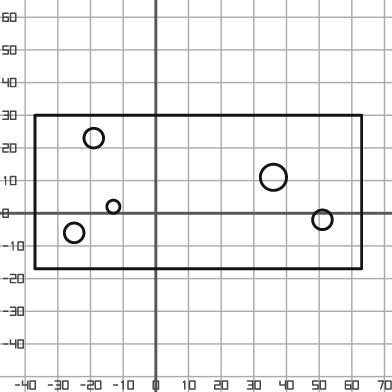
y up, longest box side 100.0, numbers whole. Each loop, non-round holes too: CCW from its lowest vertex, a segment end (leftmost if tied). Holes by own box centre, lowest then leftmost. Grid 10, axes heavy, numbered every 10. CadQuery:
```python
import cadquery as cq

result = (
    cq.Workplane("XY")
    .moveTo(-37.0, -17.0)
    .lineTo(63.0, -17.0)
    .lineTo(63.0, 30.0)
    .lineTo(-37.0, 30.0)
    .close()
    .moveTo(-25.0, -6.0)
    .circle(3.0)
    .moveTo(51.0, -2.0)
    .circle(3.0)
    .moveTo(-13.0, 2.0)
    .circle(2.0)
    .moveTo(36.0, 11.0)
    .circle(4.0)
    .moveTo(-19.0, 23.0)
    .circle(3.0)
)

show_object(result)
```